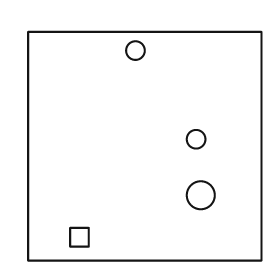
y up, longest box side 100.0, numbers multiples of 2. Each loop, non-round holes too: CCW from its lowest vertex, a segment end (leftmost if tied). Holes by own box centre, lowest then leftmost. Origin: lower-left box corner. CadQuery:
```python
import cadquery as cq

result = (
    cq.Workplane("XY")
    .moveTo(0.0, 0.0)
    .lineTo(100.0, 0.0)
    .lineTo(100.0, 98.0)
    .lineTo(0.0, 98.0)
    .close()
    .moveTo(18.0, 6.0)
    .lineTo(26.0, 6.0)
    .lineTo(26.0, 14.0)
    .lineTo(18.0, 14.0)
    .close()
    .moveTo(74.0, 28.0)
    .circle(6.0)
    .moveTo(72.0, 52.0)
    .circle(4.0)
    .moveTo(46.0, 90.0)
    .circle(4.0)
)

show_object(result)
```